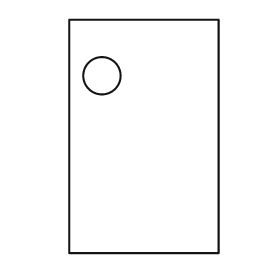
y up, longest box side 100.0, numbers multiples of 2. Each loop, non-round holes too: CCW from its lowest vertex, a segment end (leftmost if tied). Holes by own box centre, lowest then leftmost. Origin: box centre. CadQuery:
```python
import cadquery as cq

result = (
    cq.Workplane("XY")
    .moveTo(-32.0, -50.0)
    .lineTo(32.0, -50.0)
    .lineTo(32.0, 50.0)
    .lineTo(-32.0, 50.0)
    .close()
    .moveTo(-18.0, 26.0)
    .circle(8.0)
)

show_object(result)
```